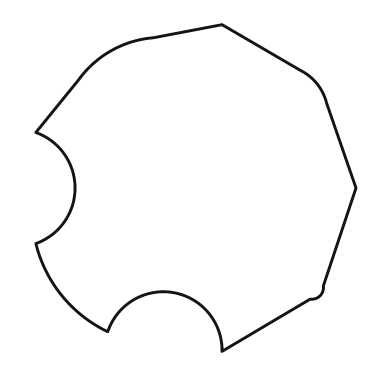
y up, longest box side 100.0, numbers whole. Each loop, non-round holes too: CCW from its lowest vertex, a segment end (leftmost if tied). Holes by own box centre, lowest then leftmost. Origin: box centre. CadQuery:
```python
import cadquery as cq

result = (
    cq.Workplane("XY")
    .moveTo(8.0, -50.0)
    .lineTo(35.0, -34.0)
    .threePointArc((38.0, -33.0), (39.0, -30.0))
    .lineTo(49.0, 0.0)
    .lineTo(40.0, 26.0)
    .threePointArc((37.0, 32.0), (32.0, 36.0))
    .lineTo(8.0, 50.0)
    .lineTo(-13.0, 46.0)
    .threePointArc((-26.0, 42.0), (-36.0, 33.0))
    .lineTo(-49.0, 17.0)
    .threePointArc((-37.0, 0.0), (-49.0, -17.0))
    .threePointArc((-41.0, -33.0), (-27.0, -44.0))
    .threePointArc((-7.0, -32.0), (8.0, -50.0))
    .close()
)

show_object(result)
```